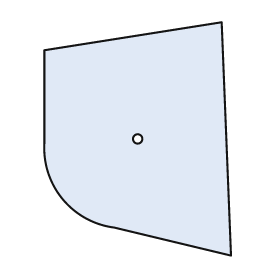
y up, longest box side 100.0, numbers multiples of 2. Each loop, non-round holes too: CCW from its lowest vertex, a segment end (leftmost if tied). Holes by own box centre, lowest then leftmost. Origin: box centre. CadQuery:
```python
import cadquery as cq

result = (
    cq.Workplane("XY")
    .moveTo(40.0, -50.0)
    .lineTo(36.0, 50.0)
    .lineTo(-40.0, 38.0)
    .lineTo(-40.0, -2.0)
    .threePointArc((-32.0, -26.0), (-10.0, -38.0))
    .close()
    .moveTo(0.0, 0.0)
    .circle(2.0)
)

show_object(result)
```